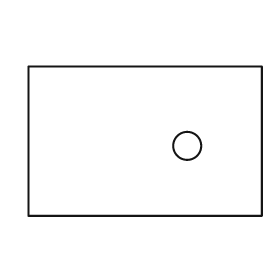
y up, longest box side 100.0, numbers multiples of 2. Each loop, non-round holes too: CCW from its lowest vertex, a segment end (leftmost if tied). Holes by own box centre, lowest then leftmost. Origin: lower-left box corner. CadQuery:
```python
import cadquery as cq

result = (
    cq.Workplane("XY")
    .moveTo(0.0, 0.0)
    .lineTo(100.0, 0.0)
    .lineTo(100.0, 64.0)
    .lineTo(0.0, 64.0)
    .close()
    .moveTo(68.0, 30.0)
    .circle(6.0)
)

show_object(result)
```